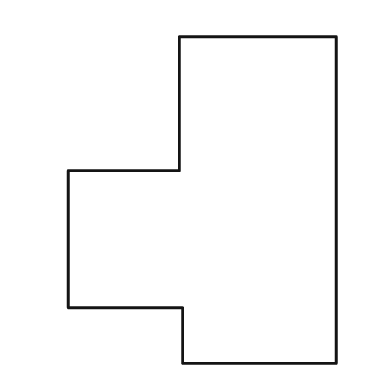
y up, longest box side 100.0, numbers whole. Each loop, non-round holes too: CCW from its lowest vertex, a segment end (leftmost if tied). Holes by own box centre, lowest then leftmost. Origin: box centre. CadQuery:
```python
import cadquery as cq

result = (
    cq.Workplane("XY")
    .moveTo(-6.0, -50.0)
    .lineTo(41.0, -50.0)
    .lineTo(41.0, 50.0)
    .lineTo(-7.0, 50.0)
    .lineTo(-7.0, 9.0)
    .lineTo(-41.0, 9.0)
    .lineTo(-41.0, -33.0)
    .lineTo(-6.0, -33.0)
    .close()
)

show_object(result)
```